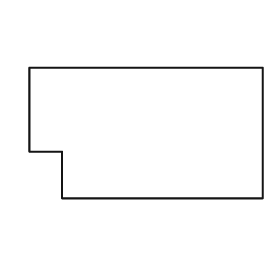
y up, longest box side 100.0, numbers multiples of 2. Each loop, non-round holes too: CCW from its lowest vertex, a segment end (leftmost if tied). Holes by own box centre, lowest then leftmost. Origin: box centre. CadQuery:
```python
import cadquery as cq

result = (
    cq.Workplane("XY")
    .moveTo(-36.0, -28.0)
    .lineTo(50.0, -28.0)
    .lineTo(50.0, 28.0)
    .lineTo(-50.0, 28.0)
    .lineTo(-50.0, -8.0)
    .lineTo(-36.0, -8.0)
    .close()
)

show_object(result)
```